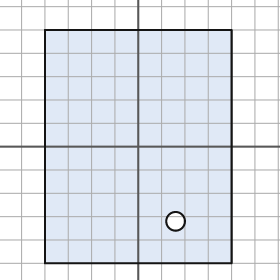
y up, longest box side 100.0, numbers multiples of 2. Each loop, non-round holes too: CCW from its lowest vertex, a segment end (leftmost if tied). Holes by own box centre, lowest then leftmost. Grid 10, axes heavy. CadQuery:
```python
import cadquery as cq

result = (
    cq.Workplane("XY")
    .moveTo(-40.0, -50.0)
    .lineTo(40.0, -50.0)
    .lineTo(40.0, 50.0)
    .lineTo(-40.0, 50.0)
    .close()
    .moveTo(16.0, -32.0)
    .circle(4.0)
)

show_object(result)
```